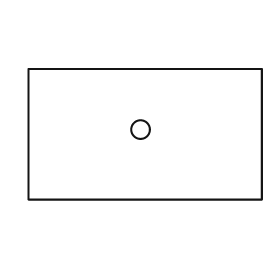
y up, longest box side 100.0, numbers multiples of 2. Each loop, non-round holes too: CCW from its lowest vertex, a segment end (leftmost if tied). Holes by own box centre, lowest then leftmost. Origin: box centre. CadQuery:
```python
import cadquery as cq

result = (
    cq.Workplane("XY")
    .moveTo(-50.0, -28.0)
    .lineTo(50.0, -28.0)
    .lineTo(50.0, 28.0)
    .lineTo(-50.0, 28.0)
    .close()
    .moveTo(-2.0, 2.0)
    .circle(4.0)
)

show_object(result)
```